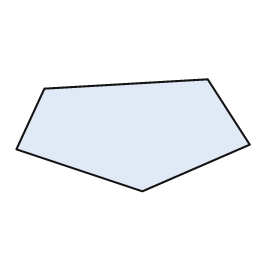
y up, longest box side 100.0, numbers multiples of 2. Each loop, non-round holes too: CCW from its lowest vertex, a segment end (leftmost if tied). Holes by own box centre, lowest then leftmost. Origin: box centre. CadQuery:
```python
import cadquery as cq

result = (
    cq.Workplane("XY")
    .moveTo(4.0, -24.0)
    .lineTo(50.0, -4.0)
    .lineTo(32.0, 24.0)
    .lineTo(-38.0, 20.0)
    .lineTo(-50.0, -6.0)
    .close()
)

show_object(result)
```